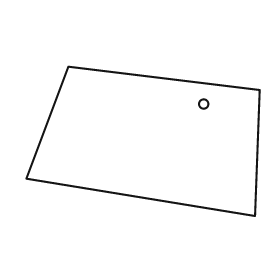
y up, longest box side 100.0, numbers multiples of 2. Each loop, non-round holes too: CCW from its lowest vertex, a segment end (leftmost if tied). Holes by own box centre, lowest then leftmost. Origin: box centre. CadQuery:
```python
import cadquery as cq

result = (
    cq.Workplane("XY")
    .moveTo(48.0, -32.0)
    .lineTo(50.0, 22.0)
    .lineTo(-32.0, 32.0)
    .lineTo(-50.0, -16.0)
    .close()
    .moveTo(26.0, 16.0)
    .circle(2.0)
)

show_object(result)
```